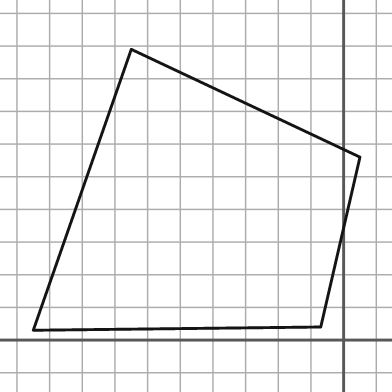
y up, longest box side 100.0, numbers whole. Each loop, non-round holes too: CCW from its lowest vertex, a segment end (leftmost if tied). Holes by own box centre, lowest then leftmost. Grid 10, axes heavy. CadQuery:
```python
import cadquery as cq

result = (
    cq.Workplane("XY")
    .moveTo(-95.0, 3.0)
    .lineTo(-7.0, 4.0)
    .lineTo(5.0, 56.0)
    .lineTo(-65.0, 89.0)
    .close()
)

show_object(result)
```